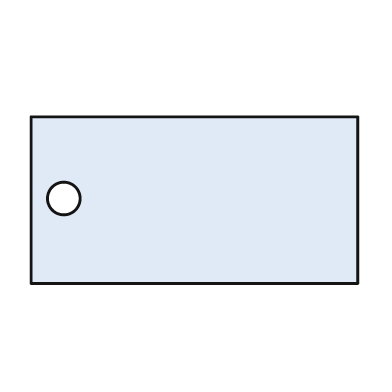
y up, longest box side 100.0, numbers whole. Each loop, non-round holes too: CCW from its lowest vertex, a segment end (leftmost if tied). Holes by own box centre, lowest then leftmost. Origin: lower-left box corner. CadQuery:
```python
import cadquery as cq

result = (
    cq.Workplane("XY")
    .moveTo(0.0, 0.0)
    .lineTo(100.0, 0.0)
    .lineTo(100.0, 51.0)
    .lineTo(0.0, 51.0)
    .close()
    .moveTo(10.0, 26.0)
    .circle(5.0)
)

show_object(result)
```